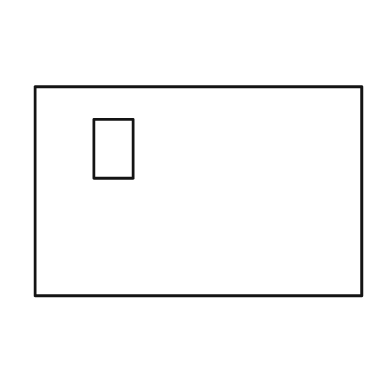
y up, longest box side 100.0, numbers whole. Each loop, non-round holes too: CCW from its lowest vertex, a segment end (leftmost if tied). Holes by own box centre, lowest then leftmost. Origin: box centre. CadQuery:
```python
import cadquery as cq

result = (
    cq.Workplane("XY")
    .moveTo(-50.0, -32.0)
    .lineTo(50.0, -32.0)
    .lineTo(50.0, 32.0)
    .lineTo(-50.0, 32.0)
    .close()
    .moveTo(-32.0, 4.0)
    .lineTo(-20.0, 4.0)
    .lineTo(-20.0, 22.0)
    .lineTo(-32.0, 22.0)
    .close()
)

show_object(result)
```